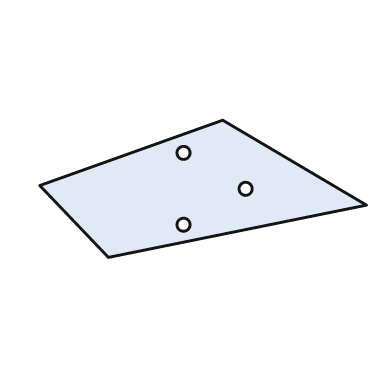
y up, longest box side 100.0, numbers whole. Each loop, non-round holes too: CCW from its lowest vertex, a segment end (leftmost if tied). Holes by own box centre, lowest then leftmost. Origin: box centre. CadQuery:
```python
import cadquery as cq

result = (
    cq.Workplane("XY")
    .moveTo(-29.0, -21.0)
    .lineTo(50.0, -5.0)
    .lineTo(6.0, 21.0)
    .lineTo(-50.0, 1.0)
    .close()
    .moveTo(-6.0, -11.0)
    .circle(2.0)
    .moveTo(13.0, 0.0)
    .circle(2.0)
    .moveTo(-6.0, 11.0)
    .circle(2.0)
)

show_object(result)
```